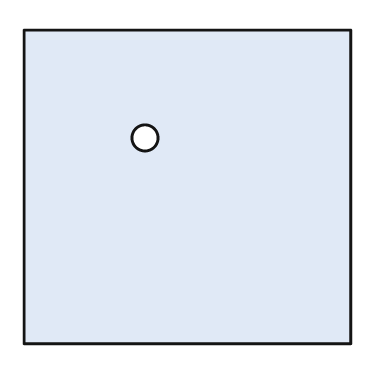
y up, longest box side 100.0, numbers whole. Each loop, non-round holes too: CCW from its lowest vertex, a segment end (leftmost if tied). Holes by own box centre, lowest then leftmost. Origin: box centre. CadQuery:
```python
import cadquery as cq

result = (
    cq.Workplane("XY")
    .moveTo(-50.0, -48.0)
    .lineTo(50.0, -48.0)
    .lineTo(50.0, 48.0)
    .lineTo(-50.0, 48.0)
    .close()
    .moveTo(-13.0, 15.0)
    .circle(4.0)
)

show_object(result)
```